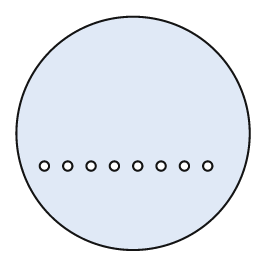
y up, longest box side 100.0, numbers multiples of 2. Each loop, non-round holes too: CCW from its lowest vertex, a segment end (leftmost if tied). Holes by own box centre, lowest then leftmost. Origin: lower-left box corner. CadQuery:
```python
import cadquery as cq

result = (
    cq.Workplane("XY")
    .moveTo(50.0, 50.0)
    .circle(50.0)
    .moveTo(12.0, 36.0)
    .circle(2.0)
    .moveTo(22.0, 36.0)
    .circle(2.0)
    .moveTo(32.0, 36.0)
    .circle(2.0)
    .moveTo(42.0, 36.0)
    .circle(2.0)
    .moveTo(52.0, 36.0)
    .circle(2.0)
    .moveTo(62.0, 36.0)
    .circle(2.0)
    .moveTo(72.0, 36.0)
    .circle(2.0)
    .moveTo(82.0, 36.0)
    .circle(2.0)
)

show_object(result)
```